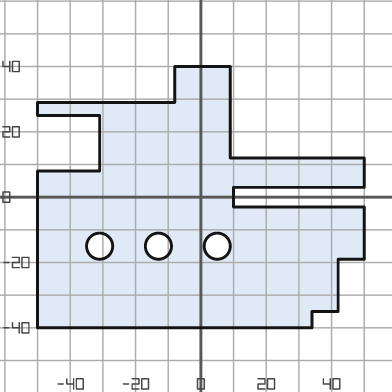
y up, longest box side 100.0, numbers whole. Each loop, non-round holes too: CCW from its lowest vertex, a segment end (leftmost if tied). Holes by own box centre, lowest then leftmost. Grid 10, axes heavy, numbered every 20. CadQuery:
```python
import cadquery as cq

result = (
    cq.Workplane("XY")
    .moveTo(-50.0, -40.0)
    .lineTo(34.0, -40.0)
    .lineTo(34.0, -35.0)
    .lineTo(42.0, -35.0)
    .lineTo(42.0, -19.0)
    .lineTo(50.0, -19.0)
    .lineTo(50.0, -3.0)
    .lineTo(10.0, -3.0)
    .lineTo(10.0, 3.0)
    .lineTo(50.0, 3.0)
    .lineTo(50.0, 12.0)
    .lineTo(9.0, 12.0)
    .lineTo(9.0, 40.0)
    .lineTo(-8.0, 40.0)
    .lineTo(-8.0, 29.0)
    .lineTo(-50.0, 29.0)
    .lineTo(-50.0, 25.0)
    .lineTo(-31.0, 25.0)
    .lineTo(-31.0, 8.0)
    .lineTo(-50.0, 8.0)
    .close()
    .moveTo(-31.0, -15.0)
    .circle(4.0)
    .moveTo(-13.0, -15.0)
    .circle(4.0)
    .moveTo(5.0, -15.0)
    .circle(4.0)
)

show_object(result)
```